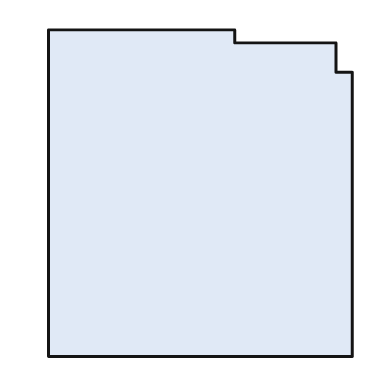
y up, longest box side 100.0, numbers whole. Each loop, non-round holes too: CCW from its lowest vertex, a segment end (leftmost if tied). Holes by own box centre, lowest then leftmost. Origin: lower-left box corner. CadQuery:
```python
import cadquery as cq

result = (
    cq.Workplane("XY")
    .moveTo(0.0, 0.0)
    .lineTo(93.0, 0.0)
    .lineTo(93.0, 87.0)
    .lineTo(88.0, 87.0)
    .lineTo(88.0, 96.0)
    .lineTo(57.0, 96.0)
    .lineTo(57.0, 100.0)
    .lineTo(0.0, 100.0)
    .close()
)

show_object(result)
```